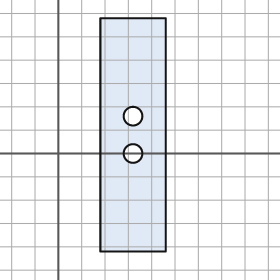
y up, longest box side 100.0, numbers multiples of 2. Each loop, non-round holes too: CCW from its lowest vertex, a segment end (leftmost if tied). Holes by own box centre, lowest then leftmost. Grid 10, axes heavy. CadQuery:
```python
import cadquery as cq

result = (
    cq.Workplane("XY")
    .moveTo(18.0, -42.0)
    .lineTo(46.0, -42.0)
    .lineTo(46.0, 58.0)
    .lineTo(18.0, 58.0)
    .close()
    .moveTo(32.0, 0.0)
    .circle(4.0)
    .moveTo(32.0, 16.0)
    .circle(4.0)
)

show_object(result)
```